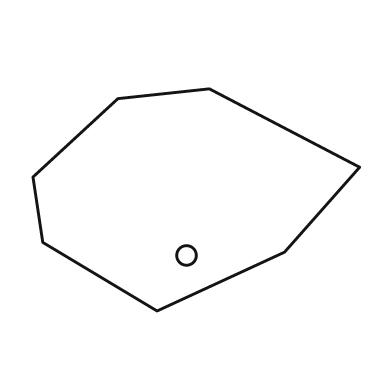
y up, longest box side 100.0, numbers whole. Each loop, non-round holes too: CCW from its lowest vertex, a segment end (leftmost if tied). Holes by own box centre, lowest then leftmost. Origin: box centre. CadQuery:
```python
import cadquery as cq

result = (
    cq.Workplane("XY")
    .moveTo(-12.0, -34.0)
    .lineTo(27.0, -16.0)
    .lineTo(50.0, 10.0)
    .lineTo(4.0, 34.0)
    .lineTo(-24.0, 31.0)
    .lineTo(-50.0, 7.0)
    .lineTo(-47.0, -13.0)
    .close()
    .moveTo(-3.0, -17.0)
    .circle(3.0)
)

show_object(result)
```